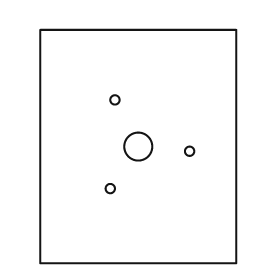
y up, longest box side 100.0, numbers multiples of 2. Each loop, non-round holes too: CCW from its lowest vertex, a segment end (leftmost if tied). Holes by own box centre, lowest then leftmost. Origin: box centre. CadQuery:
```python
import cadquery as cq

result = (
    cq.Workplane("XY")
    .moveTo(-42.0, -50.0)
    .lineTo(42.0, -50.0)
    .lineTo(42.0, 50.0)
    .lineTo(-42.0, 50.0)
    .close()
    .moveTo(-12.0, -18.0)
    .circle(2.0)
    .moveTo(22.0, -2.0)
    .circle(2.0)
    .moveTo(0.0, 0.0)
    .circle(6.0)
    .moveTo(-10.0, 20.0)
    .circle(2.0)
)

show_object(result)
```